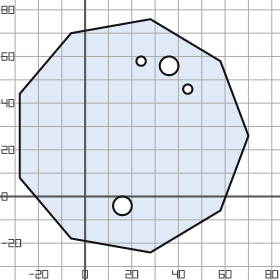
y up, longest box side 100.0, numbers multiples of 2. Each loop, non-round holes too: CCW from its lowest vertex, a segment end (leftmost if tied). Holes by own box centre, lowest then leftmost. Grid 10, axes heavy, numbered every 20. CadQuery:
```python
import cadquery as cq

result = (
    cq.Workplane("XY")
    .moveTo(28.0, -24.0)
    .lineTo(58.0, -6.0)
    .lineTo(70.0, 26.0)
    .lineTo(58.0, 58.0)
    .lineTo(28.0, 76.0)
    .lineTo(-6.0, 70.0)
    .lineTo(-28.0, 44.0)
    .lineTo(-28.0, 8.0)
    .lineTo(-6.0, -18.0)
    .close()
    .moveTo(16.0, -4.0)
    .circle(4.0)
    .moveTo(44.0, 46.0)
    .circle(2.0)
    .moveTo(36.0, 56.0)
    .circle(4.0)
    .moveTo(24.0, 58.0)
    .circle(2.0)
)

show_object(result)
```